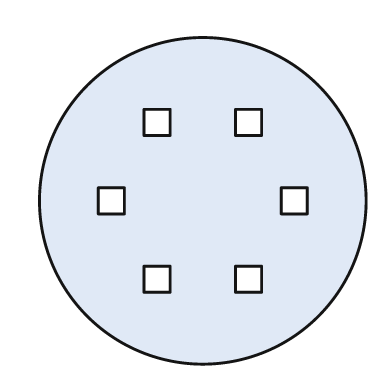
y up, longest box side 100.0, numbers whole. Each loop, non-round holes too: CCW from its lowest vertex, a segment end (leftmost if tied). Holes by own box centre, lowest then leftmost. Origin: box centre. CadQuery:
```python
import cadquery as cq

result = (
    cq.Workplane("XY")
    .moveTo(0.0, 0.0)
    .circle(50.0)
    .moveTo(-18.0, -28.0)
    .lineTo(-10.0, -28.0)
    .lineTo(-10.0, -20.0)
    .lineTo(-18.0, -20.0)
    .close()
    .moveTo(10.0, -28.0)
    .lineTo(18.0, -28.0)
    .lineTo(18.0, -20.0)
    .lineTo(10.0, -20.0)
    .close()
    .moveTo(-32.0, -4.0)
    .lineTo(-24.0, -4.0)
    .lineTo(-24.0, 4.0)
    .lineTo(-32.0, 4.0)
    .close()
    .moveTo(24.0, -4.0)
    .lineTo(32.0, -4.0)
    .lineTo(32.0, 4.0)
    .lineTo(24.0, 4.0)
    .close()
    .moveTo(-18.0, 20.0)
    .lineTo(-10.0, 20.0)
    .lineTo(-10.0, 28.0)
    .lineTo(-18.0, 28.0)
    .close()
    .moveTo(10.0, 20.0)
    .lineTo(18.0, 20.0)
    .lineTo(18.0, 28.0)
    .lineTo(10.0, 28.0)
    .close()
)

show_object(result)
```